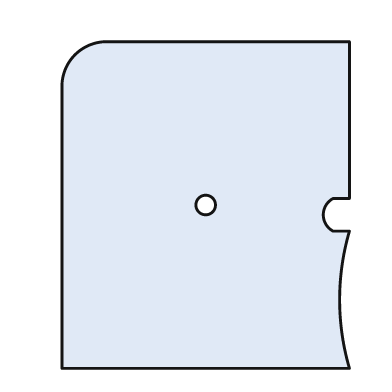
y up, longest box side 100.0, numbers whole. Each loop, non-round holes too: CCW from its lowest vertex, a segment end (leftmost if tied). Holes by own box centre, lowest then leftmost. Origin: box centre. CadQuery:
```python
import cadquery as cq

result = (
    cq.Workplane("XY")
    .moveTo(-44.0, -50.0)
    .lineTo(44.0, -50.0)
    .threePointArc((41.0, -29.0), (44.0, -8.0))
    .lineTo(39.0, -8.0)
    .threePointArc((36.0, -3.0), (39.0, 2.0))
    .lineTo(44.0, 2.0)
    .lineTo(44.0, 50.0)
    .lineTo(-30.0, 50.0)
    .threePointArc((-40.0, 46.0), (-44.0, 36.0))
    .close()
    .moveTo(0.0, 0.0)
    .circle(3.0)
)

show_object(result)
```